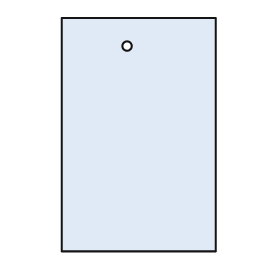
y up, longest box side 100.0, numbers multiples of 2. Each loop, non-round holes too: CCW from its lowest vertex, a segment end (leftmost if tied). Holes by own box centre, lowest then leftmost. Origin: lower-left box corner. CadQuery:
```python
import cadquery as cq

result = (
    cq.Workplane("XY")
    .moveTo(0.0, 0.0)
    .lineTo(66.0, 0.0)
    .lineTo(66.0, 100.0)
    .lineTo(0.0, 100.0)
    .close()
    .moveTo(28.0, 88.0)
    .circle(2.0)
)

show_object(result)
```